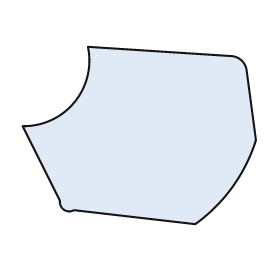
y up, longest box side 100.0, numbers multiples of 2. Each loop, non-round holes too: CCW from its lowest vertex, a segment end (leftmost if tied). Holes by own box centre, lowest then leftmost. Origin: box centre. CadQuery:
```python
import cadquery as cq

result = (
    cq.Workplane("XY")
    .moveTo(24.0, -38.0)
    .threePointArc((40.0, -22.0), (50.0, -2.0))
    .lineTo(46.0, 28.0)
    .threePointArc((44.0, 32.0), (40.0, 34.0))
    .lineTo(-22.0, 38.0)
    .threePointArc((-28.0, 14.0), (-50.0, 4.0))
    .lineTo(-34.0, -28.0)
    .threePointArc((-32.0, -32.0), (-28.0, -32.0))
    .close()
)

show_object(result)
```